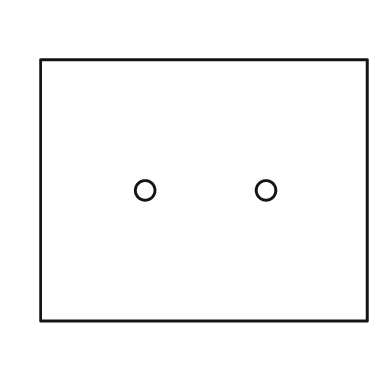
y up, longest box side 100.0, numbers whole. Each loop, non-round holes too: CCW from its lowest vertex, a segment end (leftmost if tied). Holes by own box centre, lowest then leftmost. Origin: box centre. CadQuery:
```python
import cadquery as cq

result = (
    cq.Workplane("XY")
    .moveTo(-50.0, -40.0)
    .lineTo(50.0, -40.0)
    .lineTo(50.0, 40.0)
    .lineTo(-50.0, 40.0)
    .close()
    .moveTo(-18.0, 0.0)
    .circle(3.0)
    .moveTo(19.0, 0.0)
    .circle(3.0)
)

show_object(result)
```